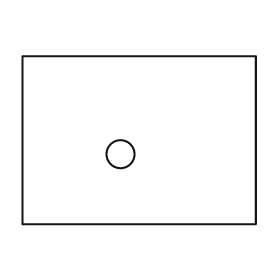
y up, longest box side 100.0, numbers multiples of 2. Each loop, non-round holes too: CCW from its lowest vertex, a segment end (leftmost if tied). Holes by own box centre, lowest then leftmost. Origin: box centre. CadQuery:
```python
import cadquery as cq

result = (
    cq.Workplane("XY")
    .moveTo(-50.0, -36.0)
    .lineTo(50.0, -36.0)
    .lineTo(50.0, 36.0)
    .lineTo(-50.0, 36.0)
    .close()
    .moveTo(-8.0, -6.0)
    .circle(6.0)
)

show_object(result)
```